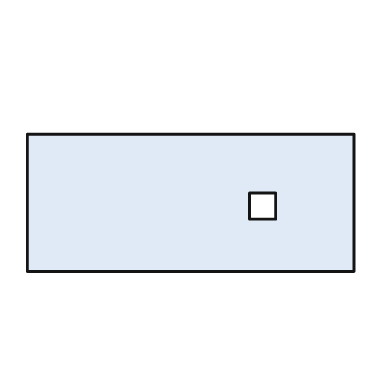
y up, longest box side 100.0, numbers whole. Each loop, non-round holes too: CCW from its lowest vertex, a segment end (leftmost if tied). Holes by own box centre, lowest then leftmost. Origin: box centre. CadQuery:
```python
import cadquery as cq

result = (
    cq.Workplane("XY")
    .moveTo(-50.0, -21.0)
    .lineTo(50.0, -21.0)
    .lineTo(50.0, 21.0)
    .lineTo(-50.0, 21.0)
    .close()
    .moveTo(18.0, -5.0)
    .lineTo(26.0, -5.0)
    .lineTo(26.0, 3.0)
    .lineTo(18.0, 3.0)
    .close()
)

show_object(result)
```